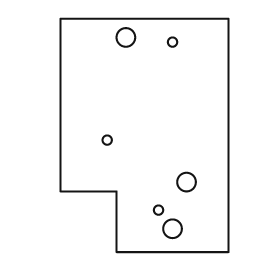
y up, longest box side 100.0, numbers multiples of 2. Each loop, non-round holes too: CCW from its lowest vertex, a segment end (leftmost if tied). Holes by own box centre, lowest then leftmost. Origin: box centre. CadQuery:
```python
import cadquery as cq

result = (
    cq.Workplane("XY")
    .moveTo(-12.0, -50.0)
    .lineTo(36.0, -50.0)
    .lineTo(36.0, 50.0)
    .lineTo(-36.0, 50.0)
    .lineTo(-36.0, -24.0)
    .lineTo(-12.0, -24.0)
    .close()
    .moveTo(12.0, -40.0)
    .circle(4.0)
    .moveTo(6.0, -32.0)
    .circle(2.0)
    .moveTo(18.0, -20.0)
    .circle(4.0)
    .moveTo(-16.0, -2.0)
    .circle(2.0)
    .moveTo(12.0, 40.0)
    .circle(2.0)
    .moveTo(-8.0, 42.0)
    .circle(4.0)
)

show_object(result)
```